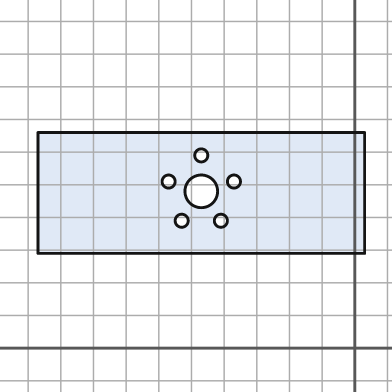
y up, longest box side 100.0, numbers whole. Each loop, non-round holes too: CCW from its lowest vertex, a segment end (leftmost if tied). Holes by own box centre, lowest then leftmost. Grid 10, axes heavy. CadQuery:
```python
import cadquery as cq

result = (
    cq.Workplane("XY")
    .moveTo(-97.0, 29.0)
    .lineTo(3.0, 29.0)
    .lineTo(3.0, 66.0)
    .lineTo(-97.0, 66.0)
    .close()
    .moveTo(-53.0, 39.0)
    .circle(2.0)
    .moveTo(-41.0, 39.0)
    .circle(2.0)
    .moveTo(-47.0, 48.0)
    .circle(5.0)
    .moveTo(-57.0, 51.0)
    .circle(2.0)
    .moveTo(-37.0, 51.0)
    .circle(2.0)
    .moveTo(-47.0, 59.0)
    .circle(2.0)
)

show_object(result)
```